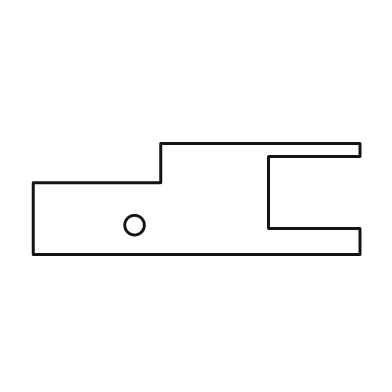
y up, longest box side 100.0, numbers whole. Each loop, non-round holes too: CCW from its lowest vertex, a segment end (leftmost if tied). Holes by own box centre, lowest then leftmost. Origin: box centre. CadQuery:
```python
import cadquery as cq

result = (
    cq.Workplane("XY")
    .moveTo(-50.0, -17.0)
    .lineTo(50.0, -17.0)
    .lineTo(50.0, -9.0)
    .lineTo(22.0, -9.0)
    .lineTo(22.0, 13.0)
    .lineTo(50.0, 13.0)
    .lineTo(50.0, 17.0)
    .lineTo(-11.0, 17.0)
    .lineTo(-11.0, 5.0)
    .lineTo(-50.0, 5.0)
    .close()
    .moveTo(-19.0, -8.0)
    .circle(3.0)
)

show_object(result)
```